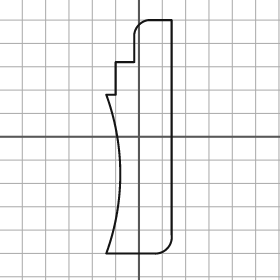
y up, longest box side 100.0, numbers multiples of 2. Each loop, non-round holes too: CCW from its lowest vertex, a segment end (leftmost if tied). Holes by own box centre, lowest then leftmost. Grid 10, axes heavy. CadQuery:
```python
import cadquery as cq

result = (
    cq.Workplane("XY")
    .moveTo(-14.0, -50.0)
    .lineTo(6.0, -50.0)
    .threePointArc((12.0, -48.0), (14.0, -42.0))
    .lineTo(14.0, 50.0)
    .lineTo(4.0, 50.0)
    .threePointArc((0.0, 48.0), (-2.0, 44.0))
    .lineTo(-2.0, 32.0)
    .lineTo(-10.0, 32.0)
    .lineTo(-10.0, 18.0)
    .lineTo(-14.0, 18.0)
    .threePointArc((-8.0, -16.0), (-14.0, -50.0))
    .close()
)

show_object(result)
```